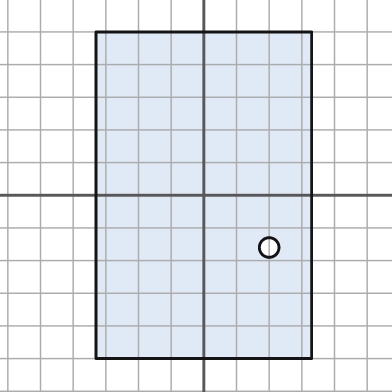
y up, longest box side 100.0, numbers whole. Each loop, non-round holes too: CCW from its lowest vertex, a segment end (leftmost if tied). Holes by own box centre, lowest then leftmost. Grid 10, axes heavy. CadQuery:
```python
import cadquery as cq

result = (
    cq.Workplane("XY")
    .moveTo(-33.0, -50.0)
    .lineTo(33.0, -50.0)
    .lineTo(33.0, 50.0)
    .lineTo(-33.0, 50.0)
    .close()
    .moveTo(20.0, -16.0)
    .circle(3.0)
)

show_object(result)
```